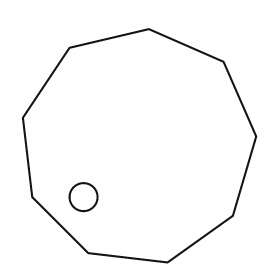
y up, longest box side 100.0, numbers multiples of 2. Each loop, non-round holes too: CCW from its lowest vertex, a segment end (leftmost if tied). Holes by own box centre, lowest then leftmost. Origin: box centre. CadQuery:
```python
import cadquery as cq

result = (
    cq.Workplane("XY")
    .moveTo(12.0, -50.0)
    .lineTo(40.0, -30.0)
    .lineTo(50.0, 4.0)
    .lineTo(36.0, 36.0)
    .lineTo(4.0, 50.0)
    .lineTo(-30.0, 42.0)
    .lineTo(-50.0, 12.0)
    .lineTo(-46.0, -22.0)
    .lineTo(-22.0, -46.0)
    .close()
    .moveTo(-24.0, -22.0)
    .circle(6.0)
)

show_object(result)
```